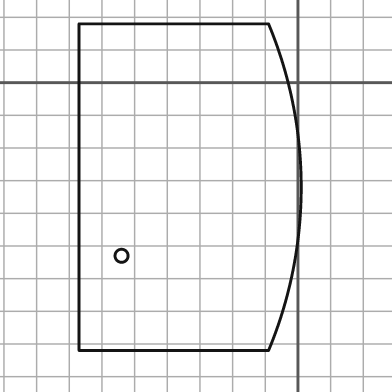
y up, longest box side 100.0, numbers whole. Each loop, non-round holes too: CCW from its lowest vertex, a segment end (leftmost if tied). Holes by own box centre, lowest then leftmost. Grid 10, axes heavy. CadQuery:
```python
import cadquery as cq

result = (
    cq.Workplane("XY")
    .moveTo(-67.0, -82.0)
    .lineTo(-9.0, -82.0)
    .threePointArc((1.0, -32.0), (-9.0, 18.0))
    .lineTo(-67.0, 18.0)
    .close()
    .moveTo(-54.0, -53.0)
    .circle(2.0)
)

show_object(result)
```